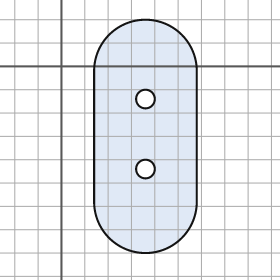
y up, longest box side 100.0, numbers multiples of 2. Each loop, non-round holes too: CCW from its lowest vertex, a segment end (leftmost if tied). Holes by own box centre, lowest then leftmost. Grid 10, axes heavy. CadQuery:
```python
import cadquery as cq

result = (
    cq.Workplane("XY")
    .moveTo(14.0, -58.0)
    .threePointArc((36.0, -80.0), (58.0, -58.0))
    .lineTo(58.0, -2.0)
    .threePointArc((36.0, 20.0), (14.0, -2.0))
    .close()
    .moveTo(36.0, -44.0)
    .circle(4.0)
    .moveTo(36.0, -14.0)
    .circle(4.0)
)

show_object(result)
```